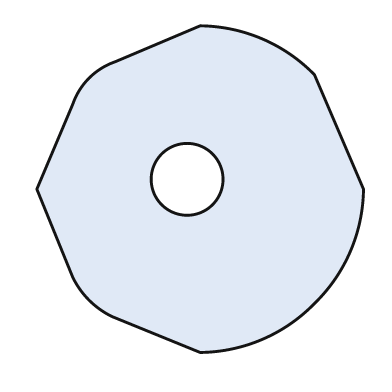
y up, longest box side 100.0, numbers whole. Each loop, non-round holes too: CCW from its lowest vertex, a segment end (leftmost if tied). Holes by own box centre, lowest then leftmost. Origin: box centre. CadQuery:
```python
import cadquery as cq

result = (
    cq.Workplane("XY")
    .moveTo(0.0, -50.0)
    .threePointArc((19.0, -46.0), (35.0, -35.0))
    .threePointArc((46.0, -19.0), (50.0, 0.0))
    .lineTo(35.0, 35.0)
    .threePointArc((19.0, 46.0), (0.0, 50.0))
    .lineTo(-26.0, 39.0)
    .threePointArc((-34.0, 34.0), (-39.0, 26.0))
    .lineTo(-50.0, 0.0)
    .lineTo(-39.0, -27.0)
    .threePointArc((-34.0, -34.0), (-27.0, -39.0))
    .close()
    .moveTo(-4.0, 3.0)
    .circle(11.0)
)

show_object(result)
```